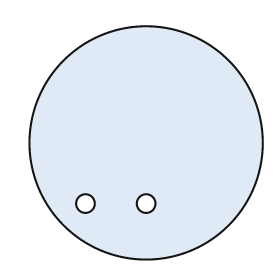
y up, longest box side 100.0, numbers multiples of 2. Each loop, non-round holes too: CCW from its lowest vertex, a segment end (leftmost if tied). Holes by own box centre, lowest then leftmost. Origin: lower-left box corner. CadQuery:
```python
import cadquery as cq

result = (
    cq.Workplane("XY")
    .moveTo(50.0, 50.0)
    .circle(50.0)
    .moveTo(24.0, 24.0)
    .circle(4.0)
    .moveTo(50.0, 24.0)
    .circle(4.0)
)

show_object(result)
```